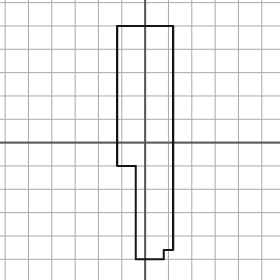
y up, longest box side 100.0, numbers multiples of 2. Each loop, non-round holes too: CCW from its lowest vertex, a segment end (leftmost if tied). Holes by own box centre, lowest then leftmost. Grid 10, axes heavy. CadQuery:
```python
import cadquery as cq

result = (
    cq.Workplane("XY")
    .moveTo(-4.0, -50.0)
    .lineTo(8.0, -50.0)
    .lineTo(8.0, -46.0)
    .lineTo(12.0, -46.0)
    .lineTo(12.0, 50.0)
    .lineTo(-12.0, 50.0)
    .lineTo(-12.0, -10.0)
    .lineTo(-4.0, -10.0)
    .close()
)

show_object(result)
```